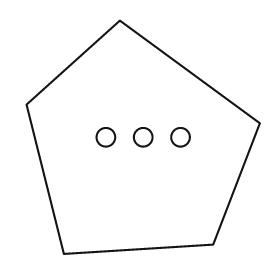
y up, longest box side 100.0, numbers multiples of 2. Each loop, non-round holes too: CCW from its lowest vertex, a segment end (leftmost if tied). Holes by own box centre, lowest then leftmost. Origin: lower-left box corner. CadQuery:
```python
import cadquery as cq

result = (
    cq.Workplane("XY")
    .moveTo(16.0, 0.0)
    .lineTo(80.0, 4.0)
    .lineTo(100.0, 56.0)
    .lineTo(40.0, 100.0)
    .lineTo(0.0, 64.0)
    .close()
    .moveTo(34.0, 50.0)
    .circle(4.0)
    .moveTo(50.0, 50.0)
    .circle(4.0)
    .moveTo(66.0, 50.0)
    .circle(4.0)
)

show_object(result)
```